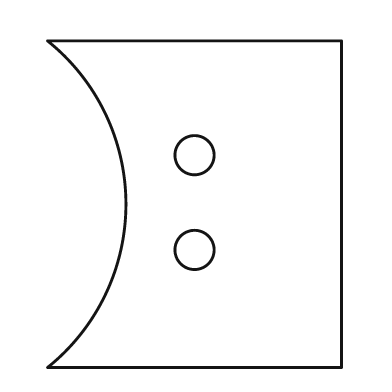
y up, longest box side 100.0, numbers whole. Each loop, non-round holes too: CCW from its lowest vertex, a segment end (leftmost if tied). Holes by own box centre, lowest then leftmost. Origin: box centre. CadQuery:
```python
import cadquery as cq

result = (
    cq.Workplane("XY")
    .moveTo(-45.0, -50.0)
    .lineTo(45.0, -50.0)
    .lineTo(45.0, 50.0)
    .lineTo(-45.0, 50.0)
    .threePointArc((-21.0, 0.0), (-45.0, -50.0))
    .close()
    .moveTo(0.0, -14.0)
    .circle(6.0)
    .moveTo(0.0, 15.0)
    .circle(6.0)
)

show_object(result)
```